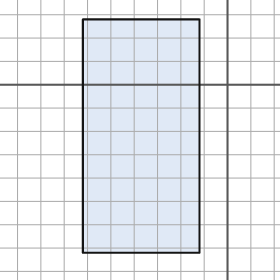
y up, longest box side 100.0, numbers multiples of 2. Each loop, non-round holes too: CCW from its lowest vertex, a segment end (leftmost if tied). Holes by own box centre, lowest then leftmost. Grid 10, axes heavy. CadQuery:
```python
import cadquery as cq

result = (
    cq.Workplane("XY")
    .moveTo(-62.0, -72.0)
    .lineTo(-12.0, -72.0)
    .lineTo(-12.0, 28.0)
    .lineTo(-62.0, 28.0)
    .close()
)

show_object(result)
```